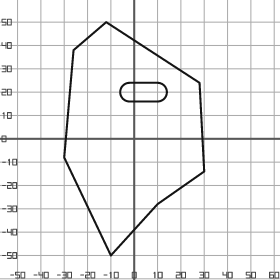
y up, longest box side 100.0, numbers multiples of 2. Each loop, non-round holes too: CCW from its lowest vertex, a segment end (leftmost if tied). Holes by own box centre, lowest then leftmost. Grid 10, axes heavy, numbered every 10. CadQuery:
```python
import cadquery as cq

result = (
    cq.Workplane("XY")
    .moveTo(-10.0, -50.0)
    .lineTo(10.0, -28.0)
    .lineTo(30.0, -14.0)
    .lineTo(28.0, 24.0)
    .lineTo(-12.0, 50.0)
    .lineTo(-26.0, 38.0)
    .lineTo(-30.0, -8.0)
    .close()
    .moveTo(-2.0, 16.0)
    .lineTo(10.0, 16.0)
    .threePointArc((14.0, 20.0), (10.0, 24.0))
    .lineTo(-2.0, 24.0)
    .threePointArc((-6.0, 20.0), (-2.0, 16.0))
    .close()
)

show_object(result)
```